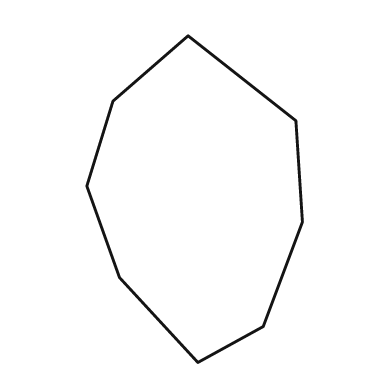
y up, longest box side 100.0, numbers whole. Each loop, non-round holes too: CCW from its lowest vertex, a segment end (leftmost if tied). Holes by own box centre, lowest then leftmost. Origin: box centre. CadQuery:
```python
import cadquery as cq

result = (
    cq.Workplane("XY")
    .moveTo(1.0, -50.0)
    .lineTo(21.0, -39.0)
    .lineTo(33.0, -7.0)
    .lineTo(31.0, 24.0)
    .lineTo(-2.0, 50.0)
    .lineTo(-25.0, 30.0)
    .lineTo(-33.0, 4.0)
    .lineTo(-23.0, -24.0)
    .close()
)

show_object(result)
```